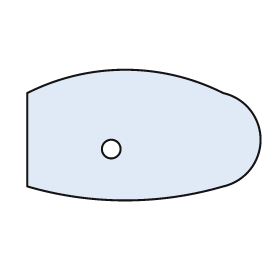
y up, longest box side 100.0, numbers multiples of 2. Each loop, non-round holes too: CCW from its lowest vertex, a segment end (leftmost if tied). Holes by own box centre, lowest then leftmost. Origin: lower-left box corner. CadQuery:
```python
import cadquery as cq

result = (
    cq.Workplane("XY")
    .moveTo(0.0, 6.0)
    .threePointArc((42.0, 0.0), (84.0, 6.0))
    .threePointArc((100.0, 26.0), (84.0, 46.0))
    .threePointArc((42.0, 56.0), (0.0, 46.0))
    .close()
    .moveTo(36.0, 22.0)
    .circle(4.0)
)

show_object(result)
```